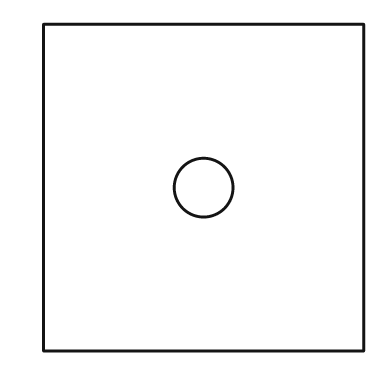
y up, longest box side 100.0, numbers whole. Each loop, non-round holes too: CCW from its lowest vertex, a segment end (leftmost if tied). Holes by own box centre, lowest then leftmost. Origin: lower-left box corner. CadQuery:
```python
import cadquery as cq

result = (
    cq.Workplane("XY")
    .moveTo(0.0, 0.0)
    .lineTo(98.0, 0.0)
    .lineTo(98.0, 100.0)
    .lineTo(0.0, 100.0)
    .close()
    .moveTo(49.0, 50.0)
    .circle(9.0)
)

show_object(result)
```